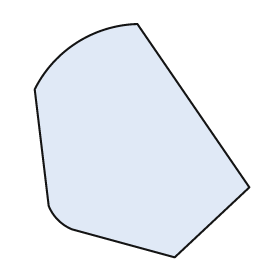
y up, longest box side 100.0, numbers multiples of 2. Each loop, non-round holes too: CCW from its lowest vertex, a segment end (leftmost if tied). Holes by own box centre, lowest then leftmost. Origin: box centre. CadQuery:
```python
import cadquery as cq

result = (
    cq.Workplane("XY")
    .moveTo(14.0, -50.0)
    .lineTo(46.0, -20.0)
    .lineTo(-2.0, 50.0)
    .threePointArc((-28.0, 42.0), (-46.0, 22.0))
    .lineTo(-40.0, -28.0)
    .threePointArc((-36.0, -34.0), (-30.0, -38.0))
    .close()
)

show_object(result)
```